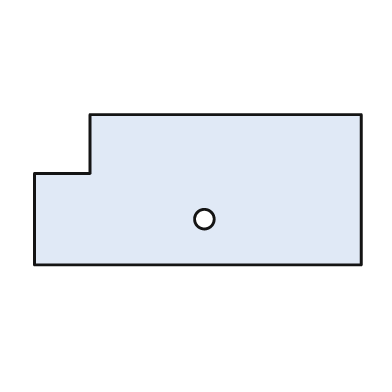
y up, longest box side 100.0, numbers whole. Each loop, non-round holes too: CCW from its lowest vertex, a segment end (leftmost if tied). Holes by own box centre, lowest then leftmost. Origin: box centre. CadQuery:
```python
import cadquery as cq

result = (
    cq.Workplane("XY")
    .moveTo(-50.0, -23.0)
    .lineTo(50.0, -23.0)
    .lineTo(50.0, 23.0)
    .lineTo(-33.0, 23.0)
    .lineTo(-33.0, 5.0)
    .lineTo(-50.0, 5.0)
    .close()
    .moveTo(2.0, -9.0)
    .circle(3.0)
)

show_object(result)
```